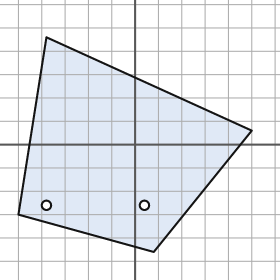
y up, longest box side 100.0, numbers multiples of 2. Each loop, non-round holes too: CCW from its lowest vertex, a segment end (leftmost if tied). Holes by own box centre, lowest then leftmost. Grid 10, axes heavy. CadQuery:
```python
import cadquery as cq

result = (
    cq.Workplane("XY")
    .moveTo(8.0, -46.0)
    .lineTo(50.0, 6.0)
    .lineTo(-38.0, 46.0)
    .lineTo(-50.0, -30.0)
    .close()
    .moveTo(-38.0, -26.0)
    .circle(2.0)
    .moveTo(4.0, -26.0)
    .circle(2.0)
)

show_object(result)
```